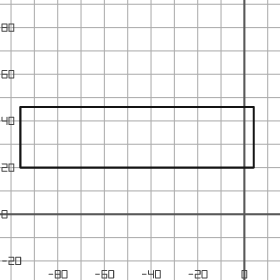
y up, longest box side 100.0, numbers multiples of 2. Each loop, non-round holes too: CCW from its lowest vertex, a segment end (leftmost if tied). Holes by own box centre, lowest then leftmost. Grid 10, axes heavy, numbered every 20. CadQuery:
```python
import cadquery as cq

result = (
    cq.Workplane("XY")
    .moveTo(-96.0, 20.0)
    .lineTo(4.0, 20.0)
    .lineTo(4.0, 46.0)
    .lineTo(-96.0, 46.0)
    .close()
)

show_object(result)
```